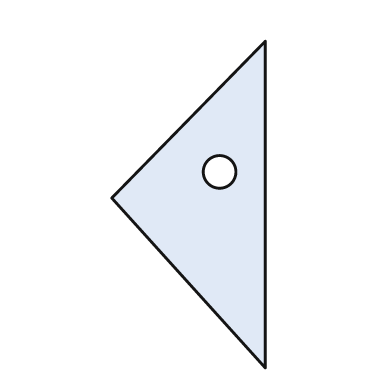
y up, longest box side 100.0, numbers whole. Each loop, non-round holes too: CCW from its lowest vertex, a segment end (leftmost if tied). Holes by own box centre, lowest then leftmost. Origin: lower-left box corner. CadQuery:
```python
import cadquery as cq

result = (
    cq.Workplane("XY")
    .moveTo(47.0, 0.0)
    .lineTo(47.0, 100.0)
    .lineTo(0.0, 52.0)
    .close()
    .moveTo(33.0, 60.0)
    .circle(5.0)
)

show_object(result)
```